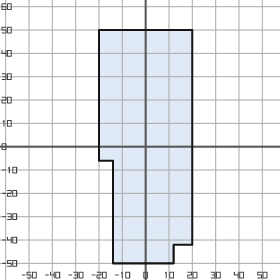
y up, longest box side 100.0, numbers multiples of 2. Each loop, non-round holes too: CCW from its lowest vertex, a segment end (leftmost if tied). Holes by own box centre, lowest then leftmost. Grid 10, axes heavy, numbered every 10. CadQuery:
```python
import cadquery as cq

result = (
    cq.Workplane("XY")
    .moveTo(-14.0, -50.0)
    .lineTo(12.0, -50.0)
    .lineTo(12.0, -42.0)
    .lineTo(20.0, -42.0)
    .lineTo(20.0, 50.0)
    .lineTo(-20.0, 50.0)
    .lineTo(-20.0, -6.0)
    .lineTo(-14.0, -6.0)
    .close()
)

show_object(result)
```